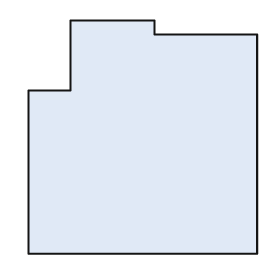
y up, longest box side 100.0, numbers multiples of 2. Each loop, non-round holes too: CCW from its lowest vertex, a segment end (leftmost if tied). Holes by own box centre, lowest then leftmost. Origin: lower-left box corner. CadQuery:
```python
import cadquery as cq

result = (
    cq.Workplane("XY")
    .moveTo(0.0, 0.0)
    .lineTo(98.0, 0.0)
    .lineTo(98.0, 94.0)
    .lineTo(54.0, 94.0)
    .lineTo(54.0, 100.0)
    .lineTo(18.0, 100.0)
    .lineTo(18.0, 70.0)
    .lineTo(0.0, 70.0)
    .close()
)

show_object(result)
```